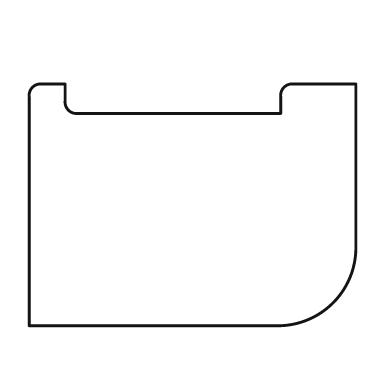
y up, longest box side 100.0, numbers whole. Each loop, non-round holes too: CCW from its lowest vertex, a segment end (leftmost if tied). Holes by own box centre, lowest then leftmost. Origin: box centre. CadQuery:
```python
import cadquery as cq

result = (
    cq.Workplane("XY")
    .moveTo(-50.0, -37.0)
    .lineTo(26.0, -37.0)
    .threePointArc((43.0, -30.0), (50.0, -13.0))
    .lineTo(50.0, 37.0)
    .lineTo(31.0, 37.0)
    .threePointArc((28.0, 36.0), (27.0, 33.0))
    .lineTo(27.0, 28.0)
    .lineTo(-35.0, 28.0)
    .threePointArc((-38.0, 29.0), (-39.0, 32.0))
    .lineTo(-39.0, 37.0)
    .lineTo(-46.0, 37.0)
    .threePointArc((-49.0, 36.0), (-50.0, 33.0))
    .close()
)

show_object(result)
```